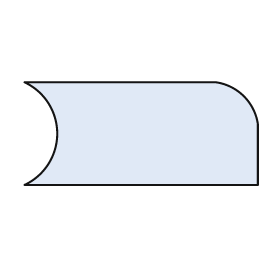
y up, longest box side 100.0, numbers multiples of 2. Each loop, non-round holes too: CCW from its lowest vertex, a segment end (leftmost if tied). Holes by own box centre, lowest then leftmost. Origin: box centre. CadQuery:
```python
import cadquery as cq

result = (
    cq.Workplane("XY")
    .moveTo(-50.0, -22.0)
    .lineTo(50.0, -22.0)
    .lineTo(50.0, 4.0)
    .threePointArc((44.0, 16.0), (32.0, 22.0))
    .lineTo(-50.0, 22.0)
    .threePointArc((-36.0, 0.0), (-50.0, -22.0))
    .close()
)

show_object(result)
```